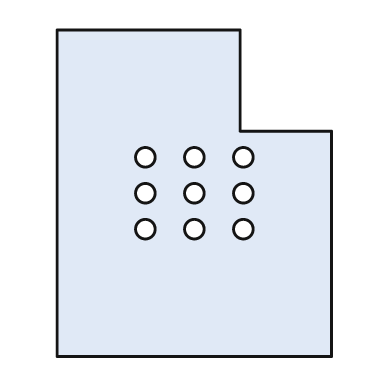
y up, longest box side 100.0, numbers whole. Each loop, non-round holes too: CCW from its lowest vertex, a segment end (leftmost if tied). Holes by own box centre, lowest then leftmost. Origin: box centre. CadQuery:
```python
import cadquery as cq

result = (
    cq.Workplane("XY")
    .moveTo(-42.0, -50.0)
    .lineTo(42.0, -50.0)
    .lineTo(42.0, 19.0)
    .lineTo(14.0, 19.0)
    .lineTo(14.0, 50.0)
    .lineTo(-42.0, 50.0)
    .close()
    .moveTo(-15.0, -11.0)
    .circle(3.0)
    .moveTo(0.0, -11.0)
    .circle(3.0)
    .moveTo(15.0, -11.0)
    .circle(3.0)
    .moveTo(-15.0, 0.0)
    .circle(3.0)
    .moveTo(0.0, 0.0)
    .circle(3.0)
    .moveTo(15.0, 0.0)
    .circle(3.0)
    .moveTo(-15.0, 11.0)
    .circle(3.0)
    .moveTo(0.0, 11.0)
    .circle(3.0)
    .moveTo(15.0, 11.0)
    .circle(3.0)
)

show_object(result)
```